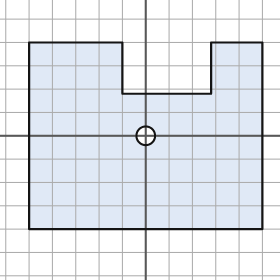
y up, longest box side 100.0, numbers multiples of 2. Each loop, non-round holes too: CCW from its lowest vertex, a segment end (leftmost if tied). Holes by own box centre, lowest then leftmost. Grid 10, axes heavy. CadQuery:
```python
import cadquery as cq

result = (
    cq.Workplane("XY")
    .moveTo(-50.0, -40.0)
    .lineTo(50.0, -40.0)
    .lineTo(50.0, 40.0)
    .lineTo(28.0, 40.0)
    .lineTo(28.0, 18.0)
    .lineTo(-10.0, 18.0)
    .lineTo(-10.0, 40.0)
    .lineTo(-50.0, 40.0)
    .close()
    .moveTo(0.0, 0.0)
    .circle(4.0)
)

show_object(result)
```